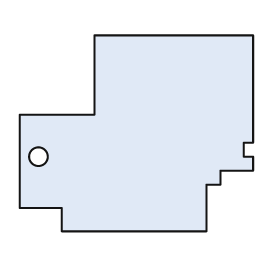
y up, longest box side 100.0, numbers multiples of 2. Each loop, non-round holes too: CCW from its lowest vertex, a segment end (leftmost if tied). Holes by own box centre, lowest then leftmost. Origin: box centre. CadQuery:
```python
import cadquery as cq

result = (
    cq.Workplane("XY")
    .moveTo(-32.0, -42.0)
    .lineTo(30.0, -42.0)
    .lineTo(30.0, -22.0)
    .lineTo(36.0, -22.0)
    .lineTo(36.0, -16.0)
    .lineTo(50.0, -16.0)
    .lineTo(50.0, -10.0)
    .lineTo(46.0, -10.0)
    .lineTo(46.0, -4.0)
    .lineTo(50.0, -4.0)
    .lineTo(50.0, 42.0)
    .lineTo(-18.0, 42.0)
    .lineTo(-18.0, 8.0)
    .lineTo(-50.0, 8.0)
    .lineTo(-50.0, -32.0)
    .lineTo(-32.0, -32.0)
    .close()
    .moveTo(-42.0, -10.0)
    .circle(4.0)
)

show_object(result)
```